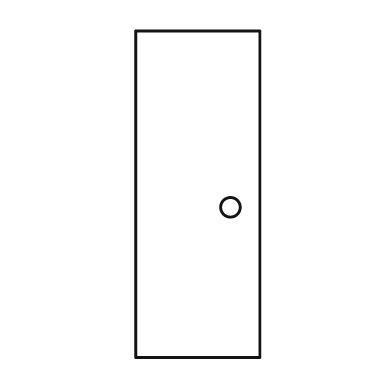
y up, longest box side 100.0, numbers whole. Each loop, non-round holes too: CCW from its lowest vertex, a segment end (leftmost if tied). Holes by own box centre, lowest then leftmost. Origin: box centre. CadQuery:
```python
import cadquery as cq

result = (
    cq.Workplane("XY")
    .moveTo(-19.0, -50.0)
    .lineTo(19.0, -50.0)
    .lineTo(19.0, 50.0)
    .lineTo(-19.0, 50.0)
    .close()
    .moveTo(10.0, -4.0)
    .circle(3.0)
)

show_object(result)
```